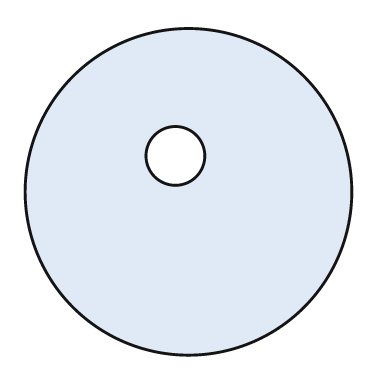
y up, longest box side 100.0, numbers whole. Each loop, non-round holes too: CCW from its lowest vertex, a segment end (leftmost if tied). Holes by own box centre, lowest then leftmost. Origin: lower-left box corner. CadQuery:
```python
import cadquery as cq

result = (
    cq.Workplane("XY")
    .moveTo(50.0, 50.0)
    .circle(50.0)
    .moveTo(46.0, 61.0)
    .circle(9.0)
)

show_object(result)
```